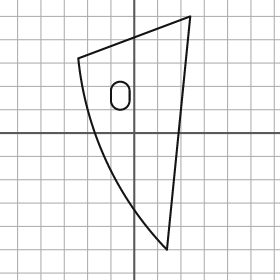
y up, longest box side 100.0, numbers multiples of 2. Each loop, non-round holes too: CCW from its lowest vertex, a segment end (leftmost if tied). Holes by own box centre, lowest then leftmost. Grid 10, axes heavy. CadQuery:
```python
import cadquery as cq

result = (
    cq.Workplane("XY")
    .moveTo(14.0, -50.0)
    .lineTo(24.0, 50.0)
    .lineTo(-24.0, 32.0)
    .threePointArc((-12.0, -12.0), (14.0, -50.0))
    .close()
    .moveTo(-10.0, 14.0)
    .threePointArc((-6.0, 10.0), (-2.0, 14.0))
    .lineTo(-2.0, 18.0)
    .threePointArc((-6.0, 22.0), (-10.0, 18.0))
    .close()
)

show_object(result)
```